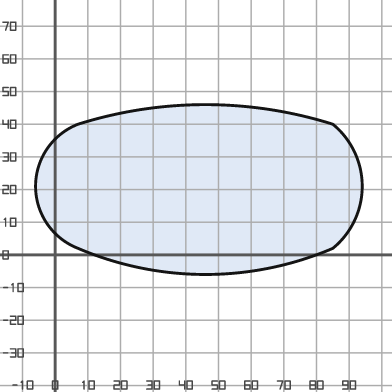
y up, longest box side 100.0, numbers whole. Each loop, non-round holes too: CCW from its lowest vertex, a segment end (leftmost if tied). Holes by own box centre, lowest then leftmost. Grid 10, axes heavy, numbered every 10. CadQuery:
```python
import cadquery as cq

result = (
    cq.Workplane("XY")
    .moveTo(7.0, 2.0)
    .threePointArc((46.0, -6.0), (85.0, 2.0))
    .threePointArc((94.0, 21.0), (85.0, 40.0))
    .threePointArc((46.0, 46.0), (7.0, 40.0))
    .threePointArc((-6.0, 21.0), (7.0, 2.0))
    .close()
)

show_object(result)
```